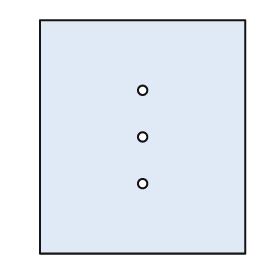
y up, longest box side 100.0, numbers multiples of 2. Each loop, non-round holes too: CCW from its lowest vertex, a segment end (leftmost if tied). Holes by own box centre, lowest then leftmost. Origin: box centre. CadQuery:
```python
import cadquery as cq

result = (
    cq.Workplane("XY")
    .moveTo(-44.0, -50.0)
    .lineTo(44.0, -50.0)
    .lineTo(44.0, 50.0)
    .lineTo(-44.0, 50.0)
    .close()
    .moveTo(0.0, -20.0)
    .circle(2.0)
    .moveTo(0.0, 0.0)
    .circle(2.0)
    .moveTo(0.0, 20.0)
    .circle(2.0)
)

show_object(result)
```